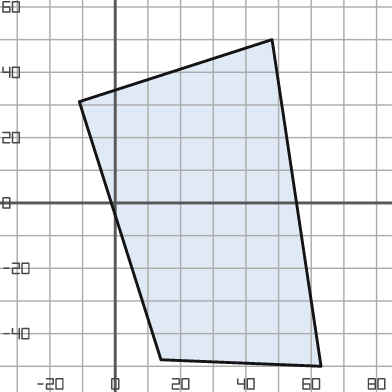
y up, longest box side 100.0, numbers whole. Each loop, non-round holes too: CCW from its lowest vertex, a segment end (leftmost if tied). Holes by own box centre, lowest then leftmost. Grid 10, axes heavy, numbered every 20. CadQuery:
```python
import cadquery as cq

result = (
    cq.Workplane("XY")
    .moveTo(63.0, -50.0)
    .lineTo(48.0, 50.0)
    .lineTo(-11.0, 31.0)
    .lineTo(14.0, -48.0)
    .close()
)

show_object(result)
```